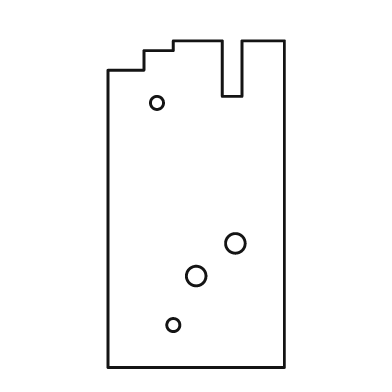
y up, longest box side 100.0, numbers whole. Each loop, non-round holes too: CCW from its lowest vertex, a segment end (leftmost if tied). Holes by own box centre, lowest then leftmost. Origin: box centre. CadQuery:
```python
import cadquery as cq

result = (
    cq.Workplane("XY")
    .moveTo(-27.0, -50.0)
    .lineTo(27.0, -50.0)
    .lineTo(27.0, 50.0)
    .lineTo(14.0, 50.0)
    .lineTo(14.0, 33.0)
    .lineTo(8.0, 33.0)
    .lineTo(8.0, 50.0)
    .lineTo(-7.0, 50.0)
    .lineTo(-7.0, 47.0)
    .lineTo(-16.0, 47.0)
    .lineTo(-16.0, 41.0)
    .lineTo(-27.0, 41.0)
    .close()
    .moveTo(-7.0, -37.0)
    .circle(2.0)
    .moveTo(0.0, -22.0)
    .circle(3.0)
    .moveTo(12.0, -12.0)
    .circle(3.0)
    .moveTo(-12.0, 31.0)
    .circle(2.0)
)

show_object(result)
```